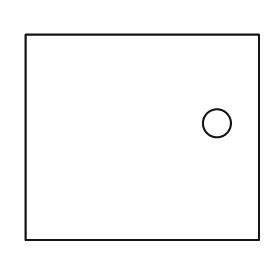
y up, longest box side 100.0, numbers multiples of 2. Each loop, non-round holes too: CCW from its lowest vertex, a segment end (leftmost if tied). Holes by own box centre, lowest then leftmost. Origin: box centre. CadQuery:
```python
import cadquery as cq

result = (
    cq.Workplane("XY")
    .moveTo(-50.0, -44.0)
    .lineTo(50.0, -44.0)
    .lineTo(50.0, 44.0)
    .lineTo(-50.0, 44.0)
    .close()
    .moveTo(32.0, 6.0)
    .circle(6.0)
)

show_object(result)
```